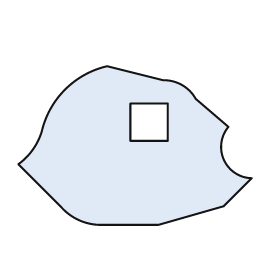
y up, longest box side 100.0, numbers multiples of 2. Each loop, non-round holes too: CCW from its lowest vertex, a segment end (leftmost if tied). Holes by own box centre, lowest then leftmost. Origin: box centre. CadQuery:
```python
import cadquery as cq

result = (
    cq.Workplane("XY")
    .moveTo(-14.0, -34.0)
    .lineTo(10.0, -34.0)
    .lineTo(38.0, -26.0)
    .lineTo(50.0, -14.0)
    .threePointArc((38.0, -6.0), (40.0, 8.0))
    .lineTo(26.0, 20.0)
    .threePointArc((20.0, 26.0), (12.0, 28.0))
    .lineTo(-12.0, 34.0)
    .threePointArc((-30.0, 24.0), (-40.0, 6.0))
    .threePointArc((-44.0, -2.0), (-50.0, -8.0))
    .lineTo(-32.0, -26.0)
    .threePointArc((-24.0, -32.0), (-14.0, -34.0))
    .close()
    .moveTo(-2.0, 2.0)
    .lineTo(14.0, 2.0)
    .lineTo(14.0, 18.0)
    .lineTo(-2.0, 18.0)
    .close()
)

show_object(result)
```